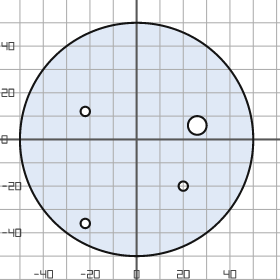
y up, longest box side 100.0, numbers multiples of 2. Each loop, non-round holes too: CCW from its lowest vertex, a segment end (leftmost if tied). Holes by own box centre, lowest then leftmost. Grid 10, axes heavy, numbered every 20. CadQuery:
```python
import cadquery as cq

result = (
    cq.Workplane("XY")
    .moveTo(0.0, 0.0)
    .circle(50.0)
    .moveTo(-22.0, -36.0)
    .circle(2.0)
    .moveTo(20.0, -20.0)
    .circle(2.0)
    .moveTo(26.0, 6.0)
    .circle(4.0)
    .moveTo(-22.0, 12.0)
    .circle(2.0)
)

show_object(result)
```